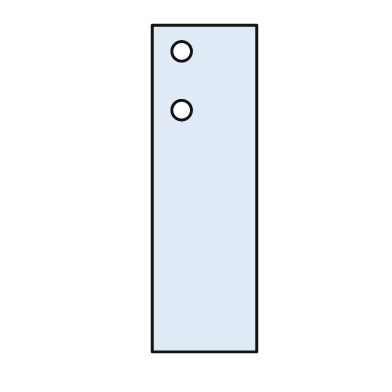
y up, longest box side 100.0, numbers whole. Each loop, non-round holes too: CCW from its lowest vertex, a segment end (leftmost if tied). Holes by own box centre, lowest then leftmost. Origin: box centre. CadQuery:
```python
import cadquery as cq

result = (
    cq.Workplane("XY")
    .moveTo(-16.0, -50.0)
    .lineTo(16.0, -50.0)
    .lineTo(16.0, 50.0)
    .lineTo(-16.0, 50.0)
    .close()
    .moveTo(-7.0, 24.0)
    .circle(3.0)
    .moveTo(-7.0, 42.0)
    .circle(3.0)
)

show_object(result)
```